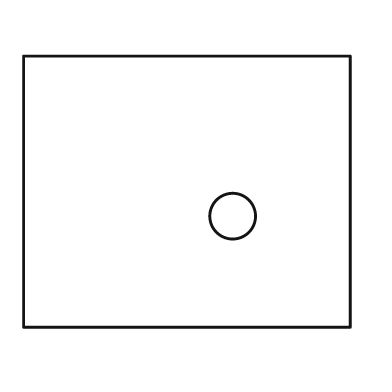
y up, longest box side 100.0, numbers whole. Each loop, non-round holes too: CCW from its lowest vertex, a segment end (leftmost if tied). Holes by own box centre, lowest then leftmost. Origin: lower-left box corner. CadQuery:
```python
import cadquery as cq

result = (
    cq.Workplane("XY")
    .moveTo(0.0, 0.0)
    .lineTo(100.0, 0.0)
    .lineTo(100.0, 83.0)
    .lineTo(0.0, 83.0)
    .close()
    .moveTo(64.0, 34.0)
    .circle(7.0)
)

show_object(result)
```